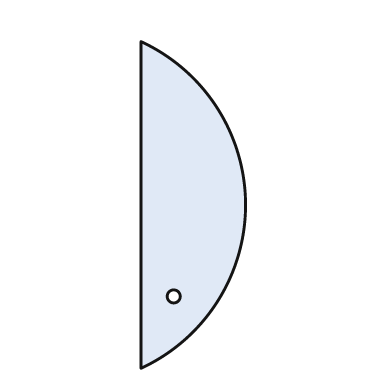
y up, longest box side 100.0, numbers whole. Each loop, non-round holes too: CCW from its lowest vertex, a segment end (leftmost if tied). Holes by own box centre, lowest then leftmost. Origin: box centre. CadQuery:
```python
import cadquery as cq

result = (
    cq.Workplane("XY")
    .moveTo(-16.0, -50.0)
    .threePointArc((16.0, 0.0), (-16.0, 50.0))
    .close()
    .moveTo(-6.0, -28.0)
    .circle(2.0)
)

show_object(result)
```